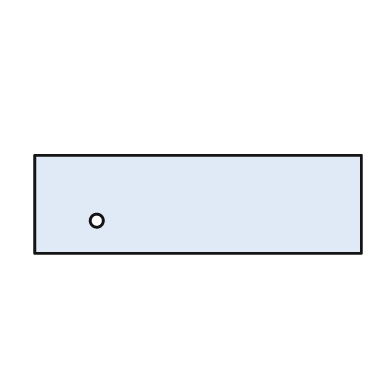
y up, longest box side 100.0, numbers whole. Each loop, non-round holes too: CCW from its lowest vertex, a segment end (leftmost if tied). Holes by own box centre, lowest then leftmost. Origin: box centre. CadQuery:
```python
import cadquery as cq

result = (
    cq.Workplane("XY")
    .moveTo(-50.0, -15.0)
    .lineTo(50.0, -15.0)
    .lineTo(50.0, 15.0)
    .lineTo(-50.0, 15.0)
    .close()
    .moveTo(-31.0, -5.0)
    .circle(2.0)
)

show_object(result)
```